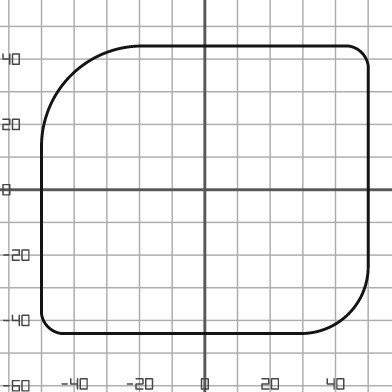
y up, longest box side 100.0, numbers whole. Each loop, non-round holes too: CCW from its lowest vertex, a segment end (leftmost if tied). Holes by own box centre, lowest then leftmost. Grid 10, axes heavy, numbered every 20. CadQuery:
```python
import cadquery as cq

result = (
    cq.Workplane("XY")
    .moveTo(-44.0, -44.0)
    .lineTo(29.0, -44.0)
    .threePointArc((44.0, -38.0), (50.0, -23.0))
    .lineTo(50.0, 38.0)
    .threePointArc((48.0, 42.0), (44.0, 44.0))
    .lineTo(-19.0, 44.0)
    .threePointArc((-41.0, 35.0), (-50.0, 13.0))
    .lineTo(-50.0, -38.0)
    .threePointArc((-48.0, -42.0), (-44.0, -44.0))
    .close()
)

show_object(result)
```